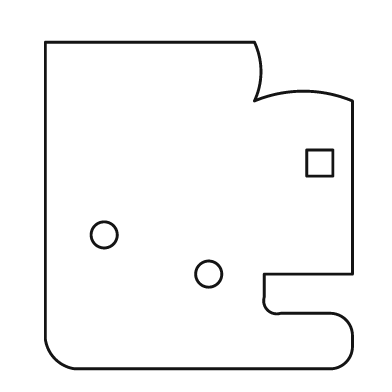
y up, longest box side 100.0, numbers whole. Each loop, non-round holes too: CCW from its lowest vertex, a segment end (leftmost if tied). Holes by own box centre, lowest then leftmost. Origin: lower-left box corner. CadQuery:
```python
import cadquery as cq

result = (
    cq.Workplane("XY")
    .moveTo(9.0, 0.0)
    .lineTo(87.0, 0.0)
    .threePointArc((92.0, 2.0), (94.0, 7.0))
    .lineTo(94.0, 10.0)
    .threePointArc((92.0, 15.0), (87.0, 17.0))
    .lineTo(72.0, 17.0)
    .threePointArc((68.0, 18.0), (67.0, 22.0))
    .lineTo(67.0, 29.0)
    .lineTo(94.0, 29.0)
    .lineTo(94.0, 82.0)
    .threePointArc((79.0, 85.0), (64.0, 82.0))
    .threePointArc((66.0, 91.0), (64.0, 100.0))
    .lineTo(0.0, 100.0)
    .lineTo(0.0, 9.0)
    .threePointArc((3.0, 3.0), (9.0, 0.0))
    .close()
    .moveTo(50.0, 29.0)
    .circle(4.0)
    .moveTo(18.0, 41.0)
    .circle(4.0)
    .moveTo(80.0, 59.0)
    .lineTo(88.0, 59.0)
    .lineTo(88.0, 67.0)
    .lineTo(80.0, 67.0)
    .close()
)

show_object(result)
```